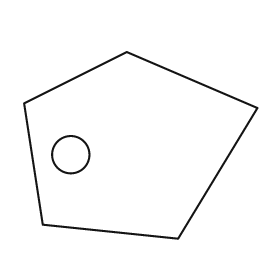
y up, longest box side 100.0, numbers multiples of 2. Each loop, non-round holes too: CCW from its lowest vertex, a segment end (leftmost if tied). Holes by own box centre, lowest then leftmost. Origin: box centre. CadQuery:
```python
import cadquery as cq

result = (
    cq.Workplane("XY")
    .moveTo(16.0, -40.0)
    .lineTo(50.0, 16.0)
    .lineTo(-6.0, 40.0)
    .lineTo(-50.0, 18.0)
    .lineTo(-42.0, -34.0)
    .close()
    .moveTo(-30.0, -4.0)
    .circle(8.0)
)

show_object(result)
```